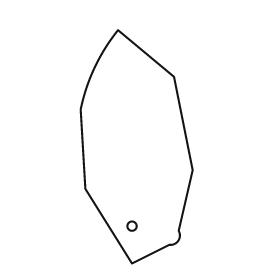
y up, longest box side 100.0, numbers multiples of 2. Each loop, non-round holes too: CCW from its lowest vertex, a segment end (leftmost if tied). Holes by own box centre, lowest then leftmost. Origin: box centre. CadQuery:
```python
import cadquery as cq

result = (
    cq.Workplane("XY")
    .moveTo(-2.0, -50.0)
    .lineTo(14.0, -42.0)
    .threePointArc((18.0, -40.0), (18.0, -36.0))
    .lineTo(24.0, -10.0)
    .lineTo(16.0, 30.0)
    .lineTo(-8.0, 50.0)
    .threePointArc((-18.0, 34.0), (-24.0, 16.0))
    .lineTo(-22.0, -18.0)
    .close()
    .moveTo(-2.0, -34.0)
    .circle(2.0)
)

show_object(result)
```